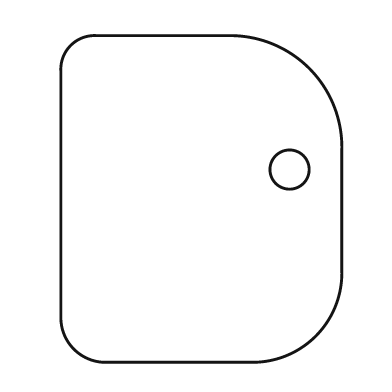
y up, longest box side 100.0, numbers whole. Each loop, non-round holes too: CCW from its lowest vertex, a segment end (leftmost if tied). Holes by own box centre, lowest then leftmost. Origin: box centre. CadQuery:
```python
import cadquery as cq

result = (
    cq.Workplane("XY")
    .moveTo(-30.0, -50.0)
    .lineTo(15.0, -50.0)
    .threePointArc((35.0, -42.0), (43.0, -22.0))
    .lineTo(43.0, 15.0)
    .threePointArc((33.0, 40.0), (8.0, 50.0))
    .lineTo(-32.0, 50.0)
    .threePointArc((-40.0, 47.0), (-43.0, 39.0))
    .lineTo(-43.0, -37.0)
    .threePointArc((-39.0, -46.0), (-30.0, -50.0))
    .close()
    .moveTo(27.0, 9.0)
    .circle(6.0)
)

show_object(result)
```